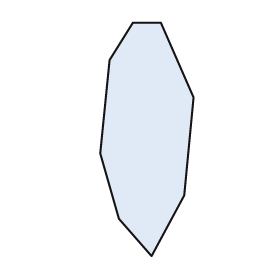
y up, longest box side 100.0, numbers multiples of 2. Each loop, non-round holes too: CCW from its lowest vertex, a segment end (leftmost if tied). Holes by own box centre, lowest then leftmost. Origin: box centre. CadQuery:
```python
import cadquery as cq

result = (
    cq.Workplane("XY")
    .moveTo(2.0, -50.0)
    .lineTo(16.0, -24.0)
    .lineTo(20.0, 18.0)
    .lineTo(6.0, 50.0)
    .lineTo(-6.0, 50.0)
    .lineTo(-16.0, 34.0)
    .lineTo(-20.0, -6.0)
    .lineTo(-12.0, -34.0)
    .close()
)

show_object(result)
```